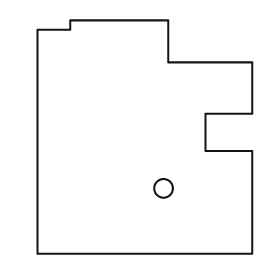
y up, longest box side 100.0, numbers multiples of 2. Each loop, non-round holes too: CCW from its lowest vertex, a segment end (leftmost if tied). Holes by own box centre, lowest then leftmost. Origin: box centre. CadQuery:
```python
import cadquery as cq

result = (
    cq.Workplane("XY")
    .moveTo(-46.0, -50.0)
    .lineTo(46.0, -50.0)
    .lineTo(46.0, -6.0)
    .lineTo(26.0, -6.0)
    .lineTo(26.0, 10.0)
    .lineTo(46.0, 10.0)
    .lineTo(46.0, 32.0)
    .lineTo(10.0, 32.0)
    .lineTo(10.0, 50.0)
    .lineTo(-32.0, 50.0)
    .lineTo(-32.0, 46.0)
    .lineTo(-46.0, 46.0)
    .close()
    .moveTo(8.0, -22.0)
    .circle(4.0)
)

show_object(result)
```